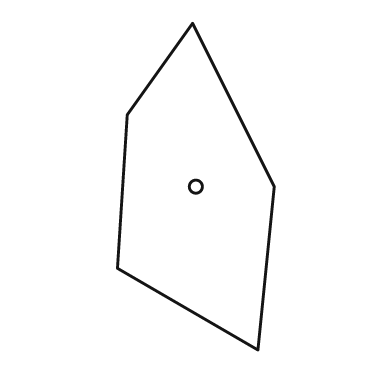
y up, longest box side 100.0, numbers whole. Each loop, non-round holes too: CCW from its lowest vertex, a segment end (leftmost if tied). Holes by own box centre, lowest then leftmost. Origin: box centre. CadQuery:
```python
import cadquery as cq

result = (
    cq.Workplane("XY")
    .moveTo(19.0, -50.0)
    .lineTo(24.0, 0.0)
    .lineTo(-1.0, 50.0)
    .lineTo(-21.0, 22.0)
    .lineTo(-24.0, -25.0)
    .close()
    .moveTo(0.0, 0.0)
    .circle(2.0)
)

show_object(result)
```